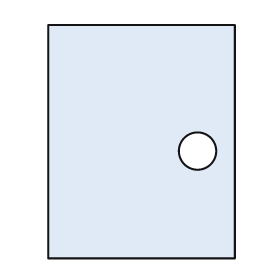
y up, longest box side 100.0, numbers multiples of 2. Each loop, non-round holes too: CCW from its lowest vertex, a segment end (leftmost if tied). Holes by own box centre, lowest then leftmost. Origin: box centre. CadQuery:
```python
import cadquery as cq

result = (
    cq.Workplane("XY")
    .moveTo(-40.0, -50.0)
    .lineTo(40.0, -50.0)
    .lineTo(40.0, 50.0)
    .lineTo(-40.0, 50.0)
    .close()
    .moveTo(24.0, -4.0)
    .circle(8.0)
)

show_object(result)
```